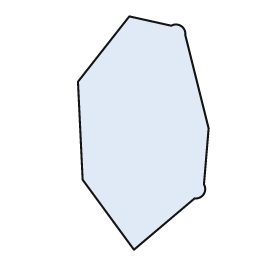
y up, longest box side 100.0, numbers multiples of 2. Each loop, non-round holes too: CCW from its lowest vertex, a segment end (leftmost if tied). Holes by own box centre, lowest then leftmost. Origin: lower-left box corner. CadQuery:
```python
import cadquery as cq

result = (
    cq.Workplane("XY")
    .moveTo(24.0, 0.0)
    .lineTo(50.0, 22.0)
    .threePointArc((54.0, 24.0), (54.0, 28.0))
    .lineTo(56.0, 52.0)
    .lineTo(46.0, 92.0)
    .threePointArc((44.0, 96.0), (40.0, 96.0))
    .lineTo(22.0, 100.0)
    .lineTo(0.0, 72.0)
    .lineTo(2.0, 30.0)
    .close()
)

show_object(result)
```